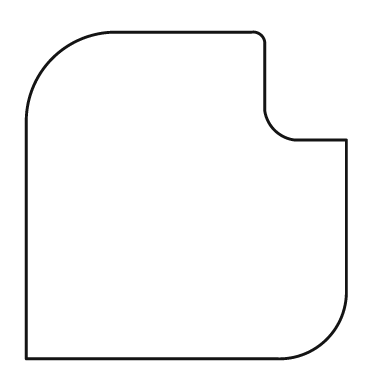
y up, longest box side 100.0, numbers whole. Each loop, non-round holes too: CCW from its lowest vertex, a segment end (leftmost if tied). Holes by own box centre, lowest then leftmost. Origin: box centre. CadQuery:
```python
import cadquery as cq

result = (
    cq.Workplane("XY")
    .moveTo(-49.0, -50.0)
    .lineTo(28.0, -50.0)
    .threePointArc((43.0, -44.0), (49.0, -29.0))
    .lineTo(49.0, 17.0)
    .lineTo(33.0, 17.0)
    .threePointArc((27.0, 20.0), (24.0, 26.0))
    .lineTo(24.0, 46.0)
    .threePointArc((23.0, 49.0), (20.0, 50.0))
    .lineTo(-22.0, 50.0)
    .threePointArc((-41.0, 42.0), (-49.0, 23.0))
    .close()
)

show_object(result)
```